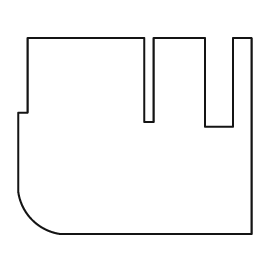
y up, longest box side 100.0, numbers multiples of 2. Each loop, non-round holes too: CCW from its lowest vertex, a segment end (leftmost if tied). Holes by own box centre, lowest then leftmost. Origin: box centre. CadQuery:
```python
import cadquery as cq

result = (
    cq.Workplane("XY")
    .moveTo(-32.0, -42.0)
    .lineTo(50.0, -42.0)
    .lineTo(50.0, 42.0)
    .lineTo(42.0, 42.0)
    .lineTo(42.0, 4.0)
    .lineTo(30.0, 4.0)
    .lineTo(30.0, 42.0)
    .lineTo(8.0, 42.0)
    .lineTo(8.0, 6.0)
    .lineTo(4.0, 6.0)
    .lineTo(4.0, 42.0)
    .lineTo(-46.0, 42.0)
    .lineTo(-46.0, 10.0)
    .lineTo(-50.0, 10.0)
    .lineTo(-50.0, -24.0)
    .threePointArc((-44.0, -36.0), (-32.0, -42.0))
    .close()
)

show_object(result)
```